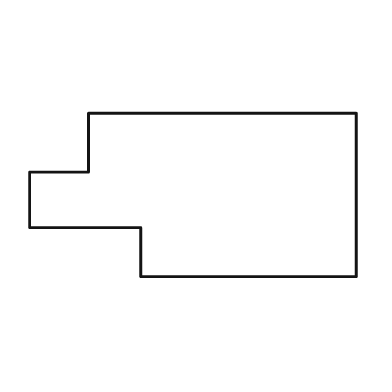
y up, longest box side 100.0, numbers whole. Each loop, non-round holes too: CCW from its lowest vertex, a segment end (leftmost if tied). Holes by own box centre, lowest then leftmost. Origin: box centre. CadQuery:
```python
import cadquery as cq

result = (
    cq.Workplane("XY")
    .moveTo(-16.0, -25.0)
    .lineTo(50.0, -25.0)
    .lineTo(50.0, 25.0)
    .lineTo(-32.0, 25.0)
    .lineTo(-32.0, 7.0)
    .lineTo(-50.0, 7.0)
    .lineTo(-50.0, -10.0)
    .lineTo(-16.0, -10.0)
    .close()
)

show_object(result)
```